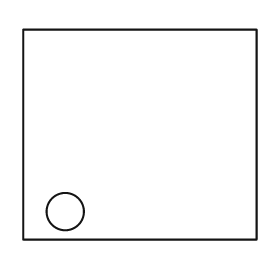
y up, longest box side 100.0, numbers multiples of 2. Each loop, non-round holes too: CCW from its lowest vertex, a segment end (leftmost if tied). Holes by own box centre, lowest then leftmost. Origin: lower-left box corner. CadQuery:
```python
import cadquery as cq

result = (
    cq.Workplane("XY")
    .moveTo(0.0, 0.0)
    .lineTo(100.0, 0.0)
    .lineTo(100.0, 90.0)
    .lineTo(0.0, 90.0)
    .close()
    .moveTo(18.0, 12.0)
    .circle(8.0)
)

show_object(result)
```